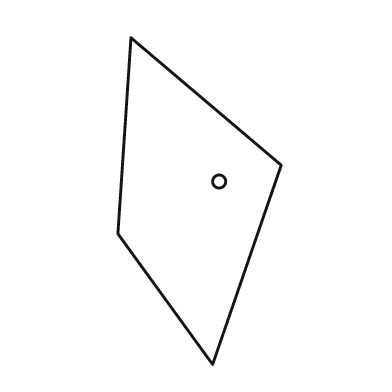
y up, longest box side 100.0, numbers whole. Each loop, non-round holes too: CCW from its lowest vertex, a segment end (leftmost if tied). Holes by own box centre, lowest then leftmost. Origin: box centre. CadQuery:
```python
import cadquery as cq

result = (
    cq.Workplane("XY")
    .moveTo(4.0, -50.0)
    .lineTo(25.0, 11.0)
    .lineTo(-21.0, 50.0)
    .lineTo(-25.0, -10.0)
    .close()
    .moveTo(6.0, 6.0)
    .circle(2.0)
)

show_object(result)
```